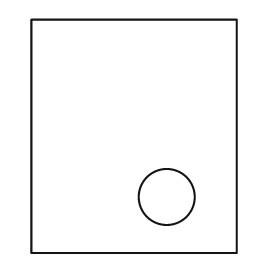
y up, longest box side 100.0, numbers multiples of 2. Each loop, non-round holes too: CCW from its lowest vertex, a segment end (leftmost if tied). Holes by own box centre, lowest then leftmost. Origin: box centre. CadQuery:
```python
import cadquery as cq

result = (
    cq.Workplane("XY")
    .moveTo(-44.0, -50.0)
    .lineTo(44.0, -50.0)
    .lineTo(44.0, 50.0)
    .lineTo(-44.0, 50.0)
    .close()
    .moveTo(14.0, -26.0)
    .circle(12.0)
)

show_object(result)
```